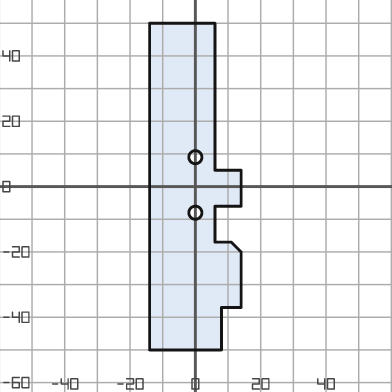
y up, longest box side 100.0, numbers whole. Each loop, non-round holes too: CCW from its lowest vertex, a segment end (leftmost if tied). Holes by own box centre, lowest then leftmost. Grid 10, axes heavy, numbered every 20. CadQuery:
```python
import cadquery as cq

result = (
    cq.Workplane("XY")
    .moveTo(-14.0, -50.0)
    .lineTo(8.0, -50.0)
    .lineTo(8.0, -37.0)
    .lineTo(14.0, -37.0)
    .lineTo(14.0, -20.0)
    .lineTo(11.0, -17.0)
    .lineTo(6.0, -17.0)
    .lineTo(6.0, -6.0)
    .lineTo(14.0, -6.0)
    .lineTo(14.0, 5.0)
    .lineTo(6.0, 5.0)
    .lineTo(6.0, 50.0)
    .lineTo(-14.0, 50.0)
    .close()
    .moveTo(0.0, -8.0)
    .circle(2.0)
    .moveTo(0.0, 9.0)
    .circle(2.0)
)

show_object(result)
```